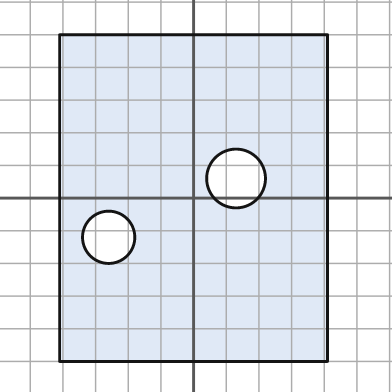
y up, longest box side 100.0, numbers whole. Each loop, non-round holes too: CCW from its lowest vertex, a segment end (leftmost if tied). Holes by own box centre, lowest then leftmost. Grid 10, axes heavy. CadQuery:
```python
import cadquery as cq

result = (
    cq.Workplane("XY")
    .moveTo(-41.0, -50.0)
    .lineTo(41.0, -50.0)
    .lineTo(41.0, 50.0)
    .lineTo(-41.0, 50.0)
    .close()
    .moveTo(-26.0, -12.0)
    .circle(8.0)
    .moveTo(13.0, 6.0)
    .circle(9.0)
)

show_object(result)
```